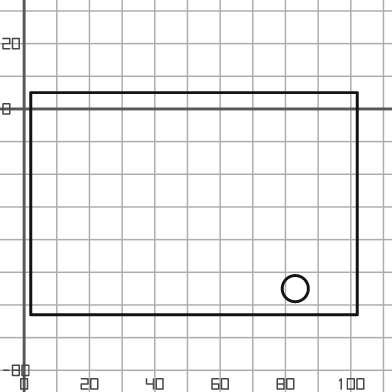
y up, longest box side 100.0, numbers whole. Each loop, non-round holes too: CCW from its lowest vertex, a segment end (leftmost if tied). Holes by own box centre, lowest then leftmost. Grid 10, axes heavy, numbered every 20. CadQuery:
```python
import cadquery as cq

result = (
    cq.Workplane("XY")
    .moveTo(2.0, -63.0)
    .lineTo(102.0, -63.0)
    .lineTo(102.0, 5.0)
    .lineTo(2.0, 5.0)
    .close()
    .moveTo(83.0, -55.0)
    .circle(4.0)
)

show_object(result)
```